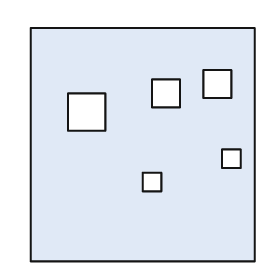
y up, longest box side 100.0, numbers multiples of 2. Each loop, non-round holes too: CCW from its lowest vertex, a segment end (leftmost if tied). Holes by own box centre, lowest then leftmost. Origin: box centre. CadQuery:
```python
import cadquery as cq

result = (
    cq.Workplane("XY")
    .moveTo(-48.0, -50.0)
    .lineTo(48.0, -50.0)
    .lineTo(48.0, 50.0)
    .lineTo(-48.0, 50.0)
    .close()
    .moveTo(0.0, -20.0)
    .lineTo(8.0, -20.0)
    .lineTo(8.0, -12.0)
    .lineTo(0.0, -12.0)
    .close()
    .moveTo(34.0, -10.0)
    .lineTo(42.0, -10.0)
    .lineTo(42.0, -2.0)
    .lineTo(34.0, -2.0)
    .close()
    .moveTo(-32.0, 6.0)
    .lineTo(-16.0, 6.0)
    .lineTo(-16.0, 22.0)
    .lineTo(-32.0, 22.0)
    .close()
    .moveTo(4.0, 16.0)
    .lineTo(16.0, 16.0)
    .lineTo(16.0, 28.0)
    .lineTo(4.0, 28.0)
    .close()
    .moveTo(26.0, 20.0)
    .lineTo(38.0, 20.0)
    .lineTo(38.0, 32.0)
    .lineTo(26.0, 32.0)
    .close()
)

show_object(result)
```